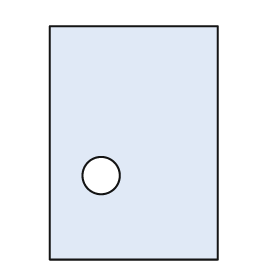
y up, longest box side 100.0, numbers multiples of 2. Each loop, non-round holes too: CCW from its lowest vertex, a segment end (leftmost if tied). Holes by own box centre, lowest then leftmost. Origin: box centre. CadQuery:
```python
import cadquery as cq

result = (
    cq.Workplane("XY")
    .moveTo(-36.0, -50.0)
    .lineTo(36.0, -50.0)
    .lineTo(36.0, 50.0)
    .lineTo(-36.0, 50.0)
    .close()
    .moveTo(-14.0, -14.0)
    .circle(8.0)
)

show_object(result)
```